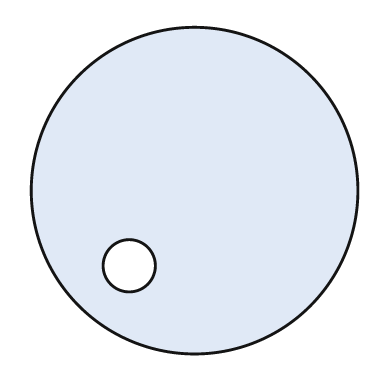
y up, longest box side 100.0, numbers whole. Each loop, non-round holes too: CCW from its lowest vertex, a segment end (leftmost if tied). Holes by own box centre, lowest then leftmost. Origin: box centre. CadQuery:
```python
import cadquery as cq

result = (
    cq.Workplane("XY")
    .moveTo(0.0, 0.0)
    .circle(50.0)
    .moveTo(-20.0, -23.0)
    .circle(8.0)
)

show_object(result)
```